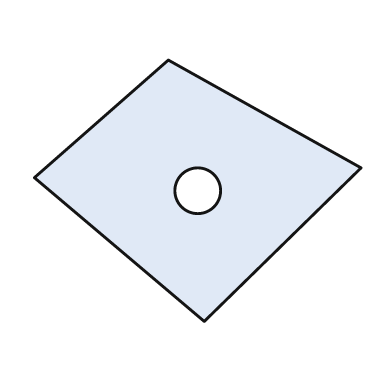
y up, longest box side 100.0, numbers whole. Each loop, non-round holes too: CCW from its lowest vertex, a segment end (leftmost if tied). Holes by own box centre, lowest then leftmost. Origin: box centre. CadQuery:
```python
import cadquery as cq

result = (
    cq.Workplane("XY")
    .moveTo(2.0, -40.0)
    .lineTo(50.0, 7.0)
    .lineTo(-9.0, 40.0)
    .lineTo(-50.0, 4.0)
    .close()
    .moveTo(0.0, 0.0)
    .circle(7.0)
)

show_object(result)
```